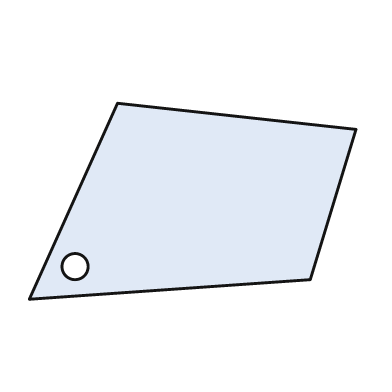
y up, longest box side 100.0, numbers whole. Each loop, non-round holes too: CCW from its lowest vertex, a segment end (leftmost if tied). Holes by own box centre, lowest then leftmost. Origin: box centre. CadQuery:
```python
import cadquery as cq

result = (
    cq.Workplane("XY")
    .moveTo(-50.0, -30.0)
    .lineTo(36.0, -24.0)
    .lineTo(50.0, 22.0)
    .lineTo(-23.0, 30.0)
    .close()
    .moveTo(-36.0, -20.0)
    .circle(4.0)
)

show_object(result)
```